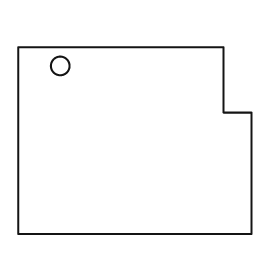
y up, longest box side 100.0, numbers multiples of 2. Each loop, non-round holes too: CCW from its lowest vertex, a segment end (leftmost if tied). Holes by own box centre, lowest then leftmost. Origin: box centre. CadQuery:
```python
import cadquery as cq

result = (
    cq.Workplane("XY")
    .moveTo(-50.0, -40.0)
    .lineTo(50.0, -40.0)
    .lineTo(50.0, 12.0)
    .lineTo(38.0, 12.0)
    .lineTo(38.0, 40.0)
    .lineTo(-50.0, 40.0)
    .close()
    .moveTo(-32.0, 32.0)
    .circle(4.0)
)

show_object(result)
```